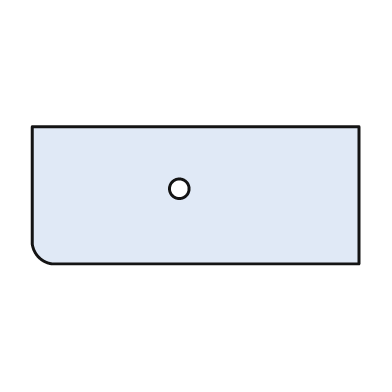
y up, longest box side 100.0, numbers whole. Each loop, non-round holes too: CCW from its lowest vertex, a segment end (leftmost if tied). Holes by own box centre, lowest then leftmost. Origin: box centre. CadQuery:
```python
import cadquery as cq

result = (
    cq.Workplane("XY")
    .moveTo(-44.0, -21.0)
    .lineTo(50.0, -21.0)
    .lineTo(50.0, 21.0)
    .lineTo(-50.0, 21.0)
    .lineTo(-50.0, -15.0)
    .threePointArc((-48.0, -19.0), (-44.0, -21.0))
    .close()
    .moveTo(-5.0, 2.0)
    .circle(3.0)
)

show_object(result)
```